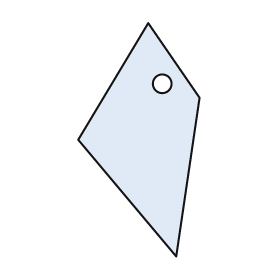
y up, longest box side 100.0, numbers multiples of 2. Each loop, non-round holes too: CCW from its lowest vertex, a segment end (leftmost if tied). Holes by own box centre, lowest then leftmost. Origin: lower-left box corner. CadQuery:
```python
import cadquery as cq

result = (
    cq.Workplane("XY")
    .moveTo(42.0, 0.0)
    .lineTo(52.0, 68.0)
    .lineTo(30.0, 100.0)
    .lineTo(0.0, 50.0)
    .close()
    .moveTo(36.0, 74.0)
    .circle(4.0)
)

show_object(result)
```